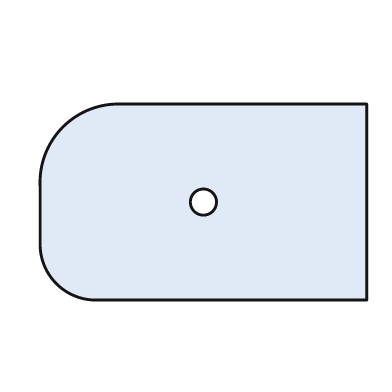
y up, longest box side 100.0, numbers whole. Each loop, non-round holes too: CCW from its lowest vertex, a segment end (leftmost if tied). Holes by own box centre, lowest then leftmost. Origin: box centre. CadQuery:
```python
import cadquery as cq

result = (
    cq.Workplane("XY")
    .moveTo(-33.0, -30.0)
    .lineTo(50.0, -30.0)
    .lineTo(50.0, 30.0)
    .lineTo(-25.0, 30.0)
    .threePointArc((-43.0, 23.0), (-50.0, 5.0))
    .lineTo(-50.0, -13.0)
    .threePointArc((-45.0, -25.0), (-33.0, -30.0))
    .close()
    .moveTo(0.0, 0.0)
    .circle(4.0)
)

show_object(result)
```